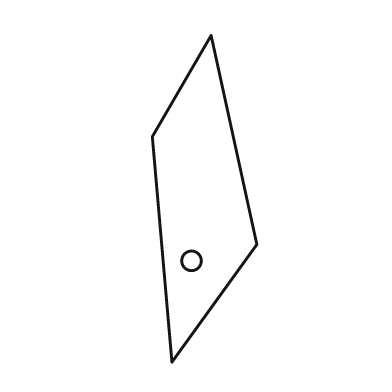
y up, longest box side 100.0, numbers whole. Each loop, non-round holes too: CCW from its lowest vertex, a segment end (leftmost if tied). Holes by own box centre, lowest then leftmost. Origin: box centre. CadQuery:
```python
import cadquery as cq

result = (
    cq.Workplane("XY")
    .moveTo(-10.0, -50.0)
    .lineTo(16.0, -14.0)
    .lineTo(2.0, 50.0)
    .lineTo(-16.0, 19.0)
    .close()
    .moveTo(-4.0, -19.0)
    .circle(3.0)
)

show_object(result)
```